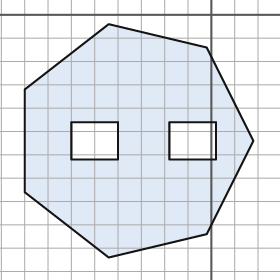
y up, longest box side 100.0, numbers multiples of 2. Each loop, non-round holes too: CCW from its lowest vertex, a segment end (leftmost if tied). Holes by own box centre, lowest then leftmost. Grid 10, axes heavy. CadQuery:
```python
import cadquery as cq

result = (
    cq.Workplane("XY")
    .moveTo(-44.0, -104.0)
    .lineTo(-2.0, -94.0)
    .lineTo(18.0, -54.0)
    .lineTo(-2.0, -14.0)
    .lineTo(-44.0, -4.0)
    .lineTo(-80.0, -32.0)
    .lineTo(-80.0, -76.0)
    .close()
    .moveTo(-60.0, -62.0)
    .lineTo(-40.0, -62.0)
    .lineTo(-40.0, -46.0)
    .lineTo(-60.0, -46.0)
    .close()
    .moveTo(-18.0, -62.0)
    .lineTo(2.0, -62.0)
    .lineTo(2.0, -46.0)
    .lineTo(-18.0, -46.0)
    .close()
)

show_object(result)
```